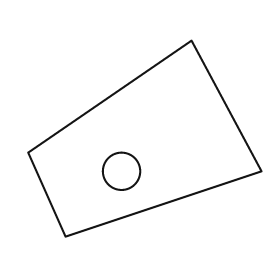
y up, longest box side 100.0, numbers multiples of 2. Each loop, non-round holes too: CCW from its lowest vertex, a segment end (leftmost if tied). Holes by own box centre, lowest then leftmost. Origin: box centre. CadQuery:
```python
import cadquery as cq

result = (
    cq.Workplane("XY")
    .moveTo(-34.0, -42.0)
    .lineTo(50.0, -14.0)
    .lineTo(20.0, 42.0)
    .lineTo(-50.0, -6.0)
    .close()
    .moveTo(-10.0, -14.0)
    .circle(8.0)
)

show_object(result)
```